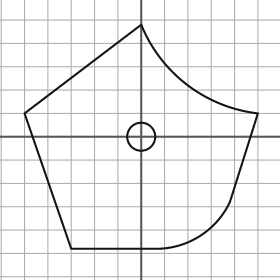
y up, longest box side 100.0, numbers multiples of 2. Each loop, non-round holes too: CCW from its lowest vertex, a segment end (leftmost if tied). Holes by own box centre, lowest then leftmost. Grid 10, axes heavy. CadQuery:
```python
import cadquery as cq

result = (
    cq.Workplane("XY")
    .moveTo(-30.0, -48.0)
    .lineTo(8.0, -48.0)
    .threePointArc((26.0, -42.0), (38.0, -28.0))
    .lineTo(50.0, 10.0)
    .threePointArc((20.0, 22.0), (0.0, 48.0))
    .lineTo(-50.0, 10.0)
    .close()
    .moveTo(0.0, 0.0)
    .circle(6.0)
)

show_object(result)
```